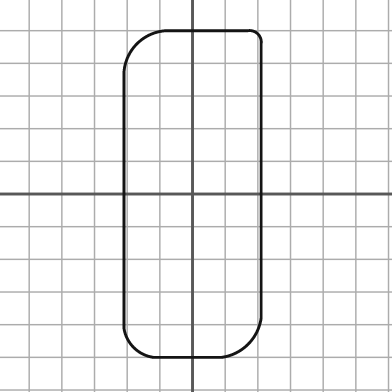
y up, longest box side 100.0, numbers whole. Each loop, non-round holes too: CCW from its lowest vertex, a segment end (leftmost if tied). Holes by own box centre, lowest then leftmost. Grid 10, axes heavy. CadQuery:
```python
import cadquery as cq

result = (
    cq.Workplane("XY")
    .moveTo(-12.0, -50.0)
    .lineTo(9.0, -50.0)
    .threePointArc((17.0, -46.0), (21.0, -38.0))
    .lineTo(21.0, 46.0)
    .threePointArc((20.0, 49.0), (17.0, 50.0))
    .lineTo(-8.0, 50.0)
    .threePointArc((-17.0, 46.0), (-21.0, 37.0))
    .lineTo(-21.0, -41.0)
    .threePointArc((-18.0, -47.0), (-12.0, -50.0))
    .close()
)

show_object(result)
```